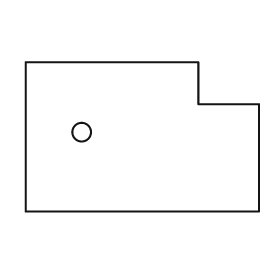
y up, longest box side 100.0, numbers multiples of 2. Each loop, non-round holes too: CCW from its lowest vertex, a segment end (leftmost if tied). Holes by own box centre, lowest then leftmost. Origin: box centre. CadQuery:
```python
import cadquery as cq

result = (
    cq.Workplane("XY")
    .moveTo(-50.0, -32.0)
    .lineTo(50.0, -32.0)
    .lineTo(50.0, 14.0)
    .lineTo(24.0, 14.0)
    .lineTo(24.0, 32.0)
    .lineTo(-50.0, 32.0)
    .close()
    .moveTo(-26.0, 2.0)
    .circle(4.0)
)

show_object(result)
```